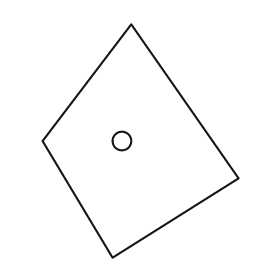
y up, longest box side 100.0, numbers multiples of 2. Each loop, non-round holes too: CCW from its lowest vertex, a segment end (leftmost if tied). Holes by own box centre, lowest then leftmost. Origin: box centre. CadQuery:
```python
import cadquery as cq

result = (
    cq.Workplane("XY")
    .moveTo(-12.0, -50.0)
    .lineTo(42.0, -16.0)
    .lineTo(-4.0, 50.0)
    .lineTo(-42.0, 0.0)
    .close()
    .moveTo(-8.0, 0.0)
    .circle(4.0)
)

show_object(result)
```